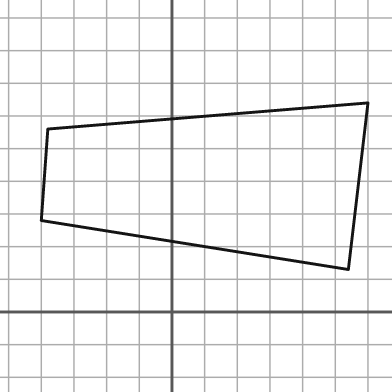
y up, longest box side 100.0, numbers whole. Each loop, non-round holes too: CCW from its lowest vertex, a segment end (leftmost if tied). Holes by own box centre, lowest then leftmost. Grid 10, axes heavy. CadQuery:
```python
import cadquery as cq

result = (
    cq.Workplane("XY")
    .moveTo(54.0, 13.0)
    .lineTo(60.0, 64.0)
    .lineTo(-38.0, 56.0)
    .lineTo(-40.0, 28.0)
    .close()
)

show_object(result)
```